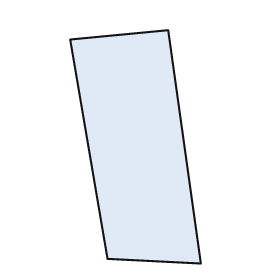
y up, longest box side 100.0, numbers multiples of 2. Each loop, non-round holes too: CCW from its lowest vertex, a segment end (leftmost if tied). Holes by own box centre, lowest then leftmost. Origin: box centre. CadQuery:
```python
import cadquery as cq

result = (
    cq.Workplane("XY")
    .moveTo(28.0, -50.0)
    .lineTo(14.0, 50.0)
    .lineTo(-28.0, 46.0)
    .lineTo(-12.0, -48.0)
    .close()
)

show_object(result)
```